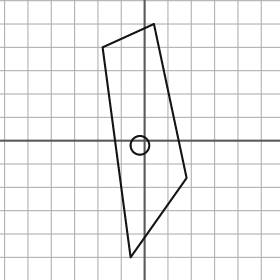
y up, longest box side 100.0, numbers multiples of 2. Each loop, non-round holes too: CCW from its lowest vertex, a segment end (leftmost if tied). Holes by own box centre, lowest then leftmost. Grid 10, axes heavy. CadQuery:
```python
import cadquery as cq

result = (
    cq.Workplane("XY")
    .moveTo(-6.0, -50.0)
    .lineTo(18.0, -16.0)
    .lineTo(4.0, 50.0)
    .lineTo(-18.0, 40.0)
    .close()
    .moveTo(-2.0, -2.0)
    .circle(4.0)
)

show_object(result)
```